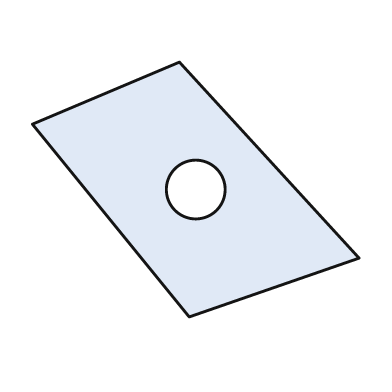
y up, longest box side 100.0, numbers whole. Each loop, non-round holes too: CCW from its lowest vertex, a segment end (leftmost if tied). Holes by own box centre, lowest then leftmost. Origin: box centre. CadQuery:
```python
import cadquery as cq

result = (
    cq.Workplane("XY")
    .moveTo(-2.0, -39.0)
    .lineTo(50.0, -21.0)
    .lineTo(-5.0, 39.0)
    .lineTo(-50.0, 20.0)
    .close()
    .moveTo(0.0, 0.0)
    .circle(9.0)
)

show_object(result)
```